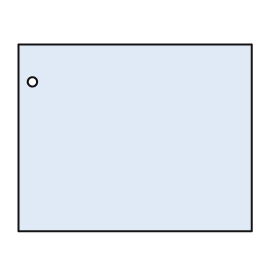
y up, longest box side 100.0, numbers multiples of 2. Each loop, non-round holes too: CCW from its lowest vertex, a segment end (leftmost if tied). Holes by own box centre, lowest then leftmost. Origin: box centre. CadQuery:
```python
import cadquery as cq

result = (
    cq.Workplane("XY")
    .moveTo(-50.0, -40.0)
    .lineTo(50.0, -40.0)
    .lineTo(50.0, 40.0)
    .lineTo(-50.0, 40.0)
    .close()
    .moveTo(-44.0, 24.0)
    .circle(2.0)
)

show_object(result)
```